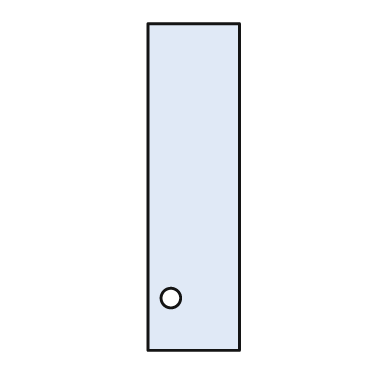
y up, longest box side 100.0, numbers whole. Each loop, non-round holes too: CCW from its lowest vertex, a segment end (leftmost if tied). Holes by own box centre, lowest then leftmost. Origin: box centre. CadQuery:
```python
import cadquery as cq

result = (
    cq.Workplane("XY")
    .moveTo(-14.0, -50.0)
    .lineTo(14.0, -50.0)
    .lineTo(14.0, 50.0)
    .lineTo(-14.0, 50.0)
    .close()
    .moveTo(-7.0, -34.0)
    .circle(3.0)
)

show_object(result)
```